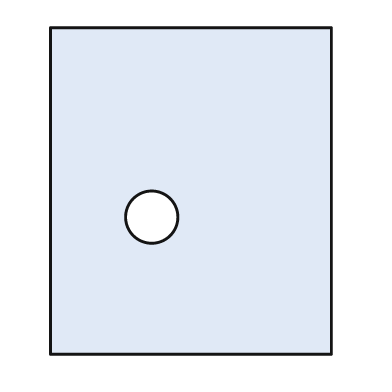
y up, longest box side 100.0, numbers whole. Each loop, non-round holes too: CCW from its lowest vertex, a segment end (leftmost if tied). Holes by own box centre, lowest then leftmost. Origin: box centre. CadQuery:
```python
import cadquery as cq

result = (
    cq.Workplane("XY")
    .moveTo(-43.0, -50.0)
    .lineTo(43.0, -50.0)
    .lineTo(43.0, 50.0)
    .lineTo(-43.0, 50.0)
    .close()
    .moveTo(-12.0, -8.0)
    .circle(8.0)
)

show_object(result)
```